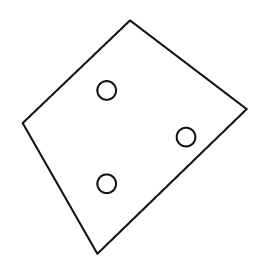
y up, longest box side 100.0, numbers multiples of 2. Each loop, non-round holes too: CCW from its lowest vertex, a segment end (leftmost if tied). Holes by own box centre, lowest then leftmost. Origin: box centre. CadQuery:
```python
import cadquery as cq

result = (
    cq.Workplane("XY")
    .moveTo(-16.0, -50.0)
    .lineTo(48.0, 12.0)
    .lineTo(-2.0, 50.0)
    .lineTo(-48.0, 6.0)
    .close()
    .moveTo(-12.0, -20.0)
    .circle(4.0)
    .moveTo(22.0, 0.0)
    .circle(4.0)
    .moveTo(-12.0, 20.0)
    .circle(4.0)
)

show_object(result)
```